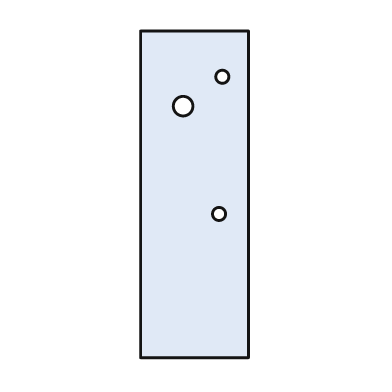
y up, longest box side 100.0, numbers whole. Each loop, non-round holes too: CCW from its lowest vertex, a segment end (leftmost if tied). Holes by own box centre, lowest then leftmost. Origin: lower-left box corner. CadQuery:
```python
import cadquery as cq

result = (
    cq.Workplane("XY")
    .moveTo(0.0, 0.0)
    .lineTo(33.0, 0.0)
    .lineTo(33.0, 100.0)
    .lineTo(0.0, 100.0)
    .close()
    .moveTo(24.0, 44.0)
    .circle(2.0)
    .moveTo(13.0, 77.0)
    .circle(3.0)
    .moveTo(25.0, 86.0)
    .circle(2.0)
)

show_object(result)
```